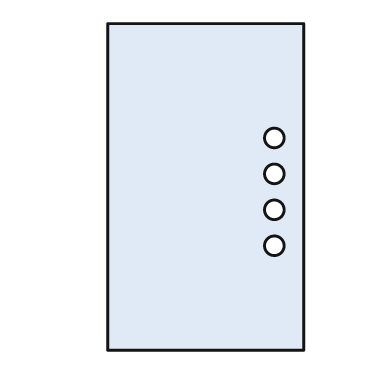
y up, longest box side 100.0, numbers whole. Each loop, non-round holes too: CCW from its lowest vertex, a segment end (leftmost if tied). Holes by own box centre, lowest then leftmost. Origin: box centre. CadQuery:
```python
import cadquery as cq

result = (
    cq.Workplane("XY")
    .moveTo(-30.0, -50.0)
    .lineTo(30.0, -50.0)
    .lineTo(30.0, 50.0)
    .lineTo(-30.0, 50.0)
    .close()
    .moveTo(21.0, -18.0)
    .circle(3.0)
    .moveTo(21.0, -7.0)
    .circle(3.0)
    .moveTo(21.0, 4.0)
    .circle(3.0)
    .moveTo(21.0, 15.0)
    .circle(3.0)
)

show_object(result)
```